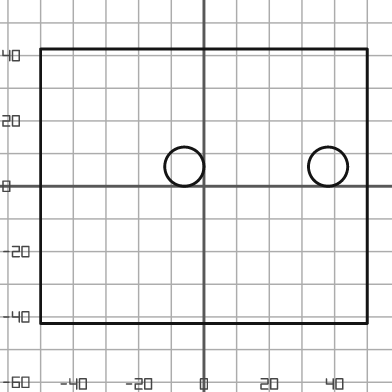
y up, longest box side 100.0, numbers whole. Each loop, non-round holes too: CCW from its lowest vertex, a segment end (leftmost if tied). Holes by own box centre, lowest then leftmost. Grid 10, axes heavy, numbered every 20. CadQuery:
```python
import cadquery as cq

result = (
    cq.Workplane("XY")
    .moveTo(-50.0, -42.0)
    .lineTo(50.0, -42.0)
    .lineTo(50.0, 42.0)
    .lineTo(-50.0, 42.0)
    .close()
    .moveTo(-6.0, 6.0)
    .circle(6.0)
    .moveTo(38.0, 6.0)
    .circle(6.0)
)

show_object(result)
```